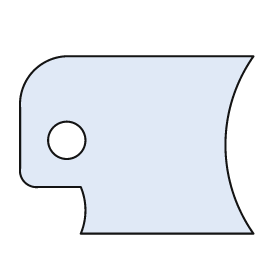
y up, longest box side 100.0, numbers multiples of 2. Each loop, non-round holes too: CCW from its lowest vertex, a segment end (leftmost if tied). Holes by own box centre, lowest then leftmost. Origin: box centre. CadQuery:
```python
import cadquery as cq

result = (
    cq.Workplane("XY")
    .moveTo(-24.0, -38.0)
    .lineTo(50.0, -38.0)
    .threePointArc((38.0, 0.0), (50.0, 38.0))
    .lineTo(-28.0, 38.0)
    .threePointArc((-44.0, 32.0), (-50.0, 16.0))
    .lineTo(-50.0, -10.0)
    .threePointArc((-48.0, -16.0), (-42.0, -18.0))
    .lineTo(-24.0, -18.0)
    .threePointArc((-22.0, -28.0), (-24.0, -38.0))
    .close()
    .moveTo(-30.0, 2.0)
    .circle(8.0)
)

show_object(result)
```